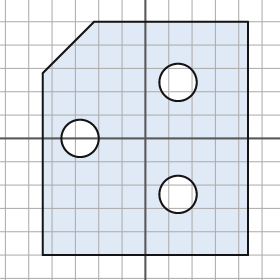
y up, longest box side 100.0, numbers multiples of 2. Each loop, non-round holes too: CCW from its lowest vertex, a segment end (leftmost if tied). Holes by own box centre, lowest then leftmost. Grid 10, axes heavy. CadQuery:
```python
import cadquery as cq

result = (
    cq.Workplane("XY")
    .moveTo(-44.0, -50.0)
    .lineTo(44.0, -50.0)
    .lineTo(44.0, 50.0)
    .lineTo(-22.0, 50.0)
    .lineTo(-44.0, 28.0)
    .close()
    .moveTo(14.0, -24.0)
    .circle(8.0)
    .moveTo(-28.0, 0.0)
    .circle(8.0)
    .moveTo(14.0, 24.0)
    .circle(8.0)
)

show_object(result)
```